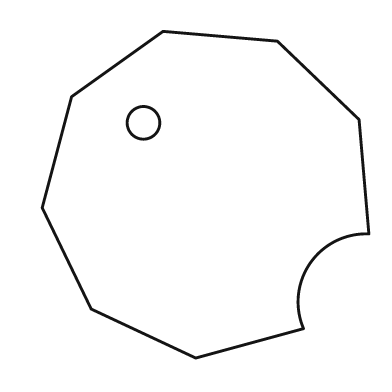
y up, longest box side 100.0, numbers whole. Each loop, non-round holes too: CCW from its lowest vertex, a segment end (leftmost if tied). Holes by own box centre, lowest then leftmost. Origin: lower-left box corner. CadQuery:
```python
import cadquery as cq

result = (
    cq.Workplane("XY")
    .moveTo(47.0, 0.0)
    .lineTo(80.0, 9.0)
    .threePointArc((82.0, 29.0), (100.0, 38.0))
    .lineTo(97.0, 73.0)
    .lineTo(72.0, 97.0)
    .lineTo(37.0, 100.0)
    .lineTo(9.0, 80.0)
    .lineTo(0.0, 46.0)
    .lineTo(15.0, 15.0)
    .close()
    .moveTo(31.0, 72.0)
    .circle(5.0)
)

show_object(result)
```